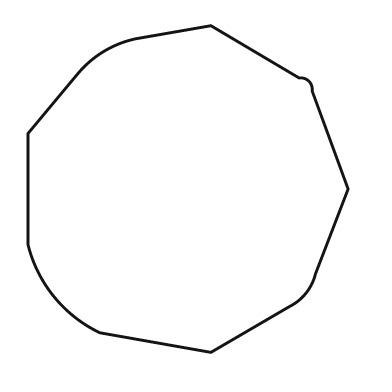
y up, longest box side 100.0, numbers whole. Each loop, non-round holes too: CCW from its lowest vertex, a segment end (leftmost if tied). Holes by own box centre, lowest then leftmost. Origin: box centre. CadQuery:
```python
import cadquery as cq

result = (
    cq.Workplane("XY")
    .moveTo(7.0, -50.0)
    .lineTo(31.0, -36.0)
    .threePointArc((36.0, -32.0), (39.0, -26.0))
    .lineTo(49.0, 0.0)
    .lineTo(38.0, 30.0)
    .threePointArc((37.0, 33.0), (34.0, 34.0))
    .lineTo(7.0, 50.0)
    .lineTo(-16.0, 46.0)
    .threePointArc((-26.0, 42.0), (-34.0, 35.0))
    .lineTo(-49.0, 17.0)
    .lineTo(-49.0, -17.0)
    .threePointArc((-41.0, -33.0), (-27.0, -44.0))
    .close()
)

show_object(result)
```